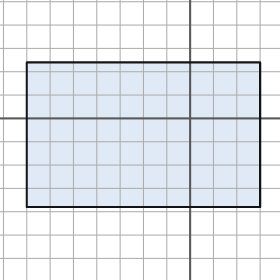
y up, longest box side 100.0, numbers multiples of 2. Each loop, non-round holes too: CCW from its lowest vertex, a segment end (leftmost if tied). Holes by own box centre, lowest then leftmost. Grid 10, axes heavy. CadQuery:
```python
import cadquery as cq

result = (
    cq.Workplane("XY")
    .moveTo(-70.0, -38.0)
    .lineTo(30.0, -38.0)
    .lineTo(30.0, 24.0)
    .lineTo(-70.0, 24.0)
    .close()
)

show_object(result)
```